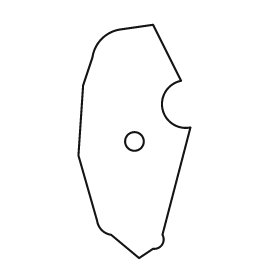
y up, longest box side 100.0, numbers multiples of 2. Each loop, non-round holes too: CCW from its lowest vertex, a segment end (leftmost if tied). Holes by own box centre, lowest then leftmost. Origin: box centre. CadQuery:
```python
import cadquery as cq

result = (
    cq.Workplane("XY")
    .moveTo(2.0, -50.0)
    .lineTo(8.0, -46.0)
    .threePointArc((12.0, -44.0), (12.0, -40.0))
    .lineTo(24.0, 6.0)
    .threePointArc((12.0, 14.0), (20.0, 26.0))
    .lineTo(8.0, 50.0)
    .lineTo(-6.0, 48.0)
    .threePointArc((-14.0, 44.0), (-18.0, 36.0))
    .lineTo(-22.0, 24.0)
    .lineTo(-24.0, -6.0)
    .lineTo(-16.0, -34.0)
    .threePointArc((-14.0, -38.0), (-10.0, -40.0))
    .close()
    .moveTo(0.0, 0.0)
    .circle(4.0)
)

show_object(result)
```